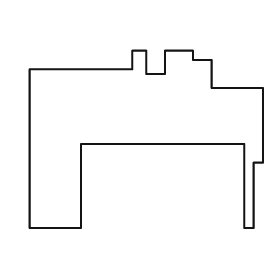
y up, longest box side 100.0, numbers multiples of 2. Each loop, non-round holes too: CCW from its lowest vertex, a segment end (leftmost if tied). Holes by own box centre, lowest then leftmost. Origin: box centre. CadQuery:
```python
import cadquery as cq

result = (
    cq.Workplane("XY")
    .moveTo(-50.0, -38.0)
    .lineTo(-28.0, -38.0)
    .lineTo(-28.0, -2.0)
    .lineTo(42.0, -2.0)
    .lineTo(42.0, -38.0)
    .lineTo(46.0, -38.0)
    .lineTo(46.0, -10.0)
    .lineTo(50.0, -10.0)
    .lineTo(50.0, 22.0)
    .lineTo(28.0, 22.0)
    .lineTo(28.0, 34.0)
    .lineTo(20.0, 34.0)
    .lineTo(20.0, 38.0)
    .lineTo(8.0, 38.0)
    .lineTo(8.0, 28.0)
    .lineTo(0.0, 28.0)
    .lineTo(0.0, 38.0)
    .lineTo(-6.0, 38.0)
    .lineTo(-6.0, 30.0)
    .lineTo(-50.0, 30.0)
    .close()
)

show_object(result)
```